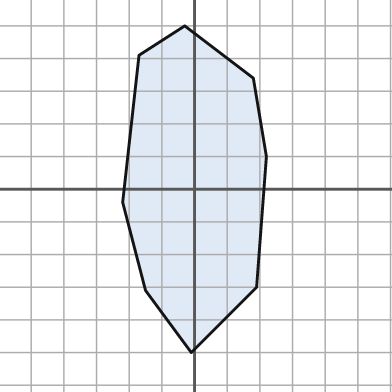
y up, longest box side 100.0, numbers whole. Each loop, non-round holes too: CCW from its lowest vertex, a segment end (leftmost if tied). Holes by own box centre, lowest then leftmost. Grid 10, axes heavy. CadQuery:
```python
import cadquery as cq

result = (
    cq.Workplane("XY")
    .moveTo(-1.0, -50.0)
    .lineTo(19.0, -30.0)
    .lineTo(22.0, 10.0)
    .lineTo(18.0, 34.0)
    .lineTo(-3.0, 50.0)
    .lineTo(-17.0, 41.0)
    .lineTo(-22.0, -4.0)
    .lineTo(-15.0, -31.0)
    .close()
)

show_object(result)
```